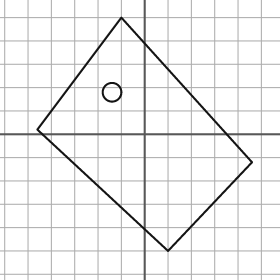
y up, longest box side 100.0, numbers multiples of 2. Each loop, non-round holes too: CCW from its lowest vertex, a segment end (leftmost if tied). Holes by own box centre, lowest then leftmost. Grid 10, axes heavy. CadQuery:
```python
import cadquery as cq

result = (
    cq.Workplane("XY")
    .moveTo(10.0, -50.0)
    .lineTo(46.0, -12.0)
    .lineTo(-10.0, 50.0)
    .lineTo(-46.0, 2.0)
    .close()
    .moveTo(-14.0, 18.0)
    .circle(4.0)
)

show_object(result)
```